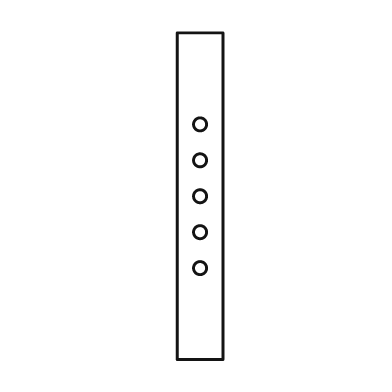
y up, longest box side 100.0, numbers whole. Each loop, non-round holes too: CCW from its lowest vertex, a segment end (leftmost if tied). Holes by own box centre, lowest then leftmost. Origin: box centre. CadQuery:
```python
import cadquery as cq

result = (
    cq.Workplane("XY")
    .moveTo(-7.0, -50.0)
    .lineTo(7.0, -50.0)
    .lineTo(7.0, 50.0)
    .lineTo(-7.0, 50.0)
    .close()
    .moveTo(0.0, -22.0)
    .circle(2.0)
    .moveTo(0.0, -11.0)
    .circle(2.0)
    .moveTo(0.0, 0.0)
    .circle(2.0)
    .moveTo(0.0, 11.0)
    .circle(2.0)
    .moveTo(0.0, 22.0)
    .circle(2.0)
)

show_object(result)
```